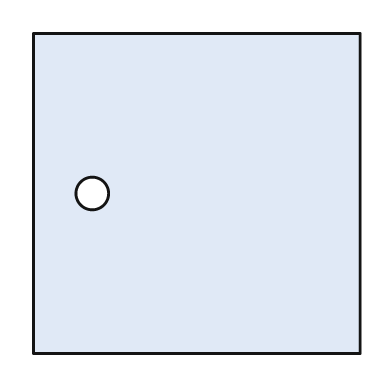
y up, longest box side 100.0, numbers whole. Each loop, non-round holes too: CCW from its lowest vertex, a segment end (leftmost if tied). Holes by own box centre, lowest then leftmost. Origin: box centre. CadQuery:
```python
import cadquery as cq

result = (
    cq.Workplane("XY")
    .moveTo(-50.0, -49.0)
    .lineTo(50.0, -49.0)
    .lineTo(50.0, 49.0)
    .lineTo(-50.0, 49.0)
    .close()
    .moveTo(-32.0, 0.0)
    .circle(5.0)
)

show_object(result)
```